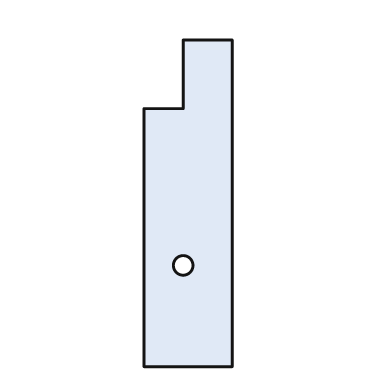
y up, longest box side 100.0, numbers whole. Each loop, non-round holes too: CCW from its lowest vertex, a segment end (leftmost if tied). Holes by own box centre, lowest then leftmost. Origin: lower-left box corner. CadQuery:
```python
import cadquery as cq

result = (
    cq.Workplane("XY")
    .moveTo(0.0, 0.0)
    .lineTo(27.0, 0.0)
    .lineTo(27.0, 100.0)
    .lineTo(12.0, 100.0)
    .lineTo(12.0, 79.0)
    .lineTo(0.0, 79.0)
    .close()
    .moveTo(12.0, 31.0)
    .circle(3.0)
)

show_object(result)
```